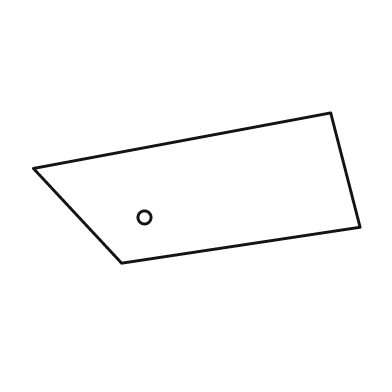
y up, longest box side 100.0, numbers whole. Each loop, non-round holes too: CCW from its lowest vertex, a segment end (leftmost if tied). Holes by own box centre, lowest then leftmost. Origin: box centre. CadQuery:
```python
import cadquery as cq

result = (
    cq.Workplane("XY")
    .moveTo(-23.0, -23.0)
    .lineTo(50.0, -12.0)
    .lineTo(41.0, 23.0)
    .lineTo(-50.0, 6.0)
    .close()
    .moveTo(-16.0, -9.0)
    .circle(2.0)
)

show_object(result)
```